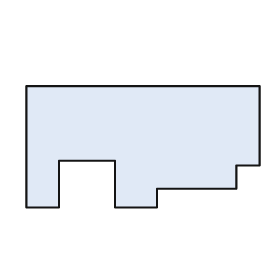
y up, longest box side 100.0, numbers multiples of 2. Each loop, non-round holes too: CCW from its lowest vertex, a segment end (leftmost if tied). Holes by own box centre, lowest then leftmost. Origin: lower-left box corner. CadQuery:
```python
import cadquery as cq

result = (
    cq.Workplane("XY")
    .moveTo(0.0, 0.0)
    .lineTo(14.0, 0.0)
    .lineTo(14.0, 20.0)
    .lineTo(38.0, 20.0)
    .lineTo(38.0, 0.0)
    .lineTo(56.0, 0.0)
    .lineTo(56.0, 8.0)
    .lineTo(90.0, 8.0)
    .lineTo(90.0, 18.0)
    .lineTo(100.0, 18.0)
    .lineTo(100.0, 52.0)
    .lineTo(0.0, 52.0)
    .close()
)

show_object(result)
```